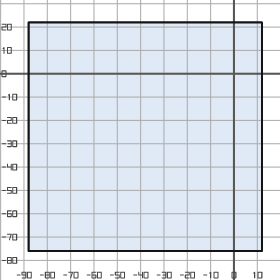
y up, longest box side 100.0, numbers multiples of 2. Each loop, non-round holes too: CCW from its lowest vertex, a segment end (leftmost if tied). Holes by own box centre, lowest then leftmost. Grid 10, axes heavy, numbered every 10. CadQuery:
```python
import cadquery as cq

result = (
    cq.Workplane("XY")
    .moveTo(-88.0, -76.0)
    .lineTo(12.0, -76.0)
    .lineTo(12.0, 22.0)
    .lineTo(-88.0, 22.0)
    .close()
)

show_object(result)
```